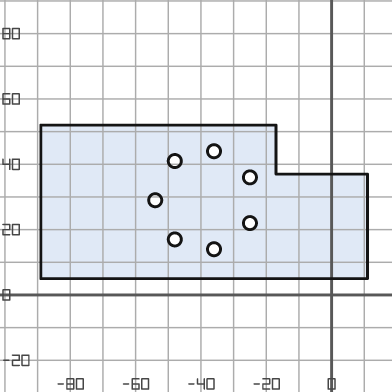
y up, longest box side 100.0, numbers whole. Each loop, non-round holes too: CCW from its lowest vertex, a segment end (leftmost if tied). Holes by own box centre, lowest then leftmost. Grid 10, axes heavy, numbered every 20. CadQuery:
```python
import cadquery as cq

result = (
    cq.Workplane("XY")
    .moveTo(-89.0, 5.0)
    .lineTo(11.0, 5.0)
    .lineTo(11.0, 37.0)
    .lineTo(-17.0, 37.0)
    .lineTo(-17.0, 52.0)
    .lineTo(-89.0, 52.0)
    .close()
    .moveTo(-36.0, 14.0)
    .circle(2.0)
    .moveTo(-48.0, 17.0)
    .circle(2.0)
    .moveTo(-25.0, 22.0)
    .circle(2.0)
    .moveTo(-54.0, 29.0)
    .circle(2.0)
    .moveTo(-25.0, 36.0)
    .circle(2.0)
    .moveTo(-48.0, 41.0)
    .circle(2.0)
    .moveTo(-36.0, 44.0)
    .circle(2.0)
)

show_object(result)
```